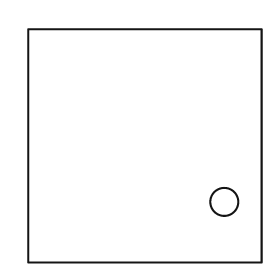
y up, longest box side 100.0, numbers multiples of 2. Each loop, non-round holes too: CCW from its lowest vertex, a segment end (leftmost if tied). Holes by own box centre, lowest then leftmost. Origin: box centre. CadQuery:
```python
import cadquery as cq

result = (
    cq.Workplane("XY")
    .moveTo(-50.0, -50.0)
    .lineTo(50.0, -50.0)
    .lineTo(50.0, 50.0)
    .lineTo(-50.0, 50.0)
    .close()
    .moveTo(34.0, -24.0)
    .circle(6.0)
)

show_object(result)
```